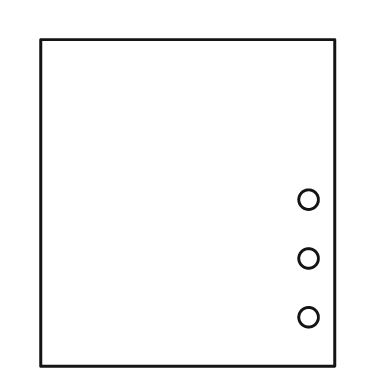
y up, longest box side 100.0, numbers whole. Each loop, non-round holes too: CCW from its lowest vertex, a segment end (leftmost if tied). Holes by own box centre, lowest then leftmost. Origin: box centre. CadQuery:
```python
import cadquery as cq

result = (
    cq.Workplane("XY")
    .moveTo(-45.0, -50.0)
    .lineTo(45.0, -50.0)
    .lineTo(45.0, 50.0)
    .lineTo(-45.0, 50.0)
    .close()
    .moveTo(37.0, -35.0)
    .circle(3.0)
    .moveTo(37.0, -17.0)
    .circle(3.0)
    .moveTo(37.0, 1.0)
    .circle(3.0)
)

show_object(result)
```